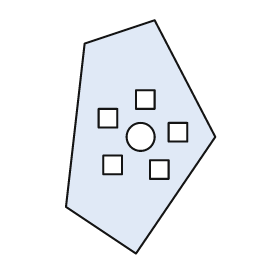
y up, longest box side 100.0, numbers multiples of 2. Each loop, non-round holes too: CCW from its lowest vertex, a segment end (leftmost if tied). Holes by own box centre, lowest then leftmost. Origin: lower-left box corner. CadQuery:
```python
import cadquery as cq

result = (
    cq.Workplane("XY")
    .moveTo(30.0, 0.0)
    .lineTo(64.0, 50.0)
    .lineTo(38.0, 100.0)
    .lineTo(8.0, 90.0)
    .lineTo(0.0, 20.0)
    .close()
    .moveTo(36.0, 32.0)
    .lineTo(44.0, 32.0)
    .lineTo(44.0, 40.0)
    .lineTo(36.0, 40.0)
    .close()
    .moveTo(16.0, 34.0)
    .lineTo(24.0, 34.0)
    .lineTo(24.0, 42.0)
    .lineTo(16.0, 42.0)
    .close()
    .moveTo(32.0, 50.0)
    .circle(6.0)
    .moveTo(44.0, 48.0)
    .lineTo(52.0, 48.0)
    .lineTo(52.0, 56.0)
    .lineTo(44.0, 56.0)
    .close()
    .moveTo(14.0, 54.0)
    .lineTo(22.0, 54.0)
    .lineTo(22.0, 62.0)
    .lineTo(14.0, 62.0)
    .close()
    .moveTo(30.0, 62.0)
    .lineTo(38.0, 62.0)
    .lineTo(38.0, 70.0)
    .lineTo(30.0, 70.0)
    .close()
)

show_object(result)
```